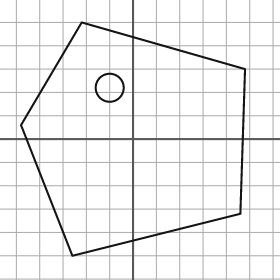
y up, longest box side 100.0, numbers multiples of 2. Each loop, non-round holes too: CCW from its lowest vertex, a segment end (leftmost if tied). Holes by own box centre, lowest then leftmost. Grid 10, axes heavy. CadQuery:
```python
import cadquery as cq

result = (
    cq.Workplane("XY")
    .moveTo(-26.0, -50.0)
    .lineTo(46.0, -32.0)
    .lineTo(48.0, 30.0)
    .lineTo(-22.0, 50.0)
    .lineTo(-48.0, 6.0)
    .close()
    .moveTo(-10.0, 22.0)
    .circle(6.0)
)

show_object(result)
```